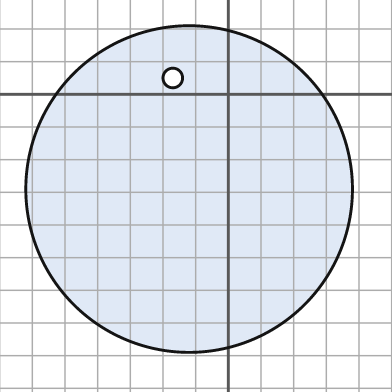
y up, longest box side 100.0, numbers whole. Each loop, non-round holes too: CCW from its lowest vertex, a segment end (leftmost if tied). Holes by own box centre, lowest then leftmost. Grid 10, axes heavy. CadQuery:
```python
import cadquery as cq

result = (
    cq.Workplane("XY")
    .moveTo(-12.0, -29.0)
    .circle(50.0)
    .moveTo(-17.0, 5.0)
    .circle(3.0)
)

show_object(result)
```